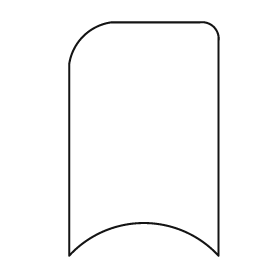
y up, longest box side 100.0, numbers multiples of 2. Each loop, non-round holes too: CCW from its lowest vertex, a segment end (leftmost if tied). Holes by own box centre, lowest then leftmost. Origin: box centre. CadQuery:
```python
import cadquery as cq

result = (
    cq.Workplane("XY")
    .moveTo(-32.0, -50.0)
    .threePointArc((0.0, -36.0), (32.0, -50.0))
    .lineTo(32.0, 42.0)
    .threePointArc((30.0, 48.0), (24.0, 50.0))
    .lineTo(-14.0, 50.0)
    .threePointArc((-26.0, 44.0), (-32.0, 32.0))
    .close()
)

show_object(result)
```